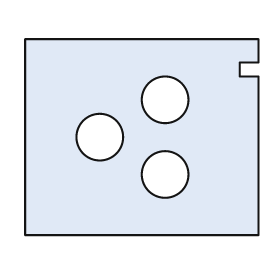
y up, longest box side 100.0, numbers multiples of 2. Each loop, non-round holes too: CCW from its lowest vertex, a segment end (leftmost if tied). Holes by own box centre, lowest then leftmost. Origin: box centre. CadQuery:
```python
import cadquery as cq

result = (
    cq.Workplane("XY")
    .moveTo(-50.0, -42.0)
    .lineTo(50.0, -42.0)
    .lineTo(50.0, 26.0)
    .lineTo(42.0, 26.0)
    .lineTo(42.0, 32.0)
    .lineTo(50.0, 32.0)
    .lineTo(50.0, 42.0)
    .lineTo(-50.0, 42.0)
    .close()
    .moveTo(10.0, -16.0)
    .circle(10.0)
    .moveTo(-18.0, 0.0)
    .circle(10.0)
    .moveTo(10.0, 16.0)
    .circle(10.0)
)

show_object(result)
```